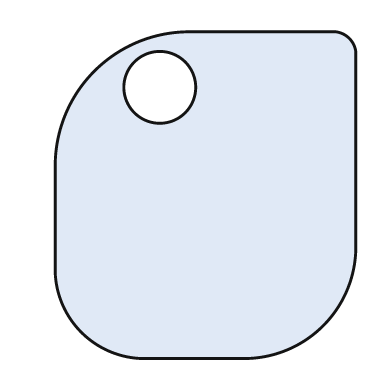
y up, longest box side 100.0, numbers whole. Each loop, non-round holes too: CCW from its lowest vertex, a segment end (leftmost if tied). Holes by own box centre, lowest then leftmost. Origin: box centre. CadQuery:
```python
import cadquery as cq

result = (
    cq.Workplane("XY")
    .moveTo(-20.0, -50.0)
    .lineTo(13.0, -50.0)
    .threePointArc((36.0, -40.0), (46.0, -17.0))
    .lineTo(46.0, 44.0)
    .threePointArc((44.0, 48.0), (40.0, 50.0))
    .lineTo(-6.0, 50.0)
    .threePointArc((-34.0, 38.0), (-46.0, 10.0))
    .lineTo(-46.0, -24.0)
    .threePointArc((-38.0, -42.0), (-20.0, -50.0))
    .close()
    .moveTo(-14.0, 33.0)
    .circle(11.0)
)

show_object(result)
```